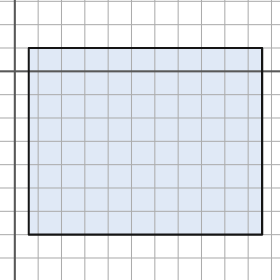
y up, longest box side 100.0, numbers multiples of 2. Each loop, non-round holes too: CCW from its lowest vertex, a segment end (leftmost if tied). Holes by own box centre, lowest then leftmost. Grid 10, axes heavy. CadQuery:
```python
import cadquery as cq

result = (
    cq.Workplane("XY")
    .moveTo(6.0, -70.0)
    .lineTo(106.0, -70.0)
    .lineTo(106.0, 10.0)
    .lineTo(6.0, 10.0)
    .close()
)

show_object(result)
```